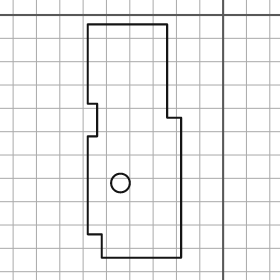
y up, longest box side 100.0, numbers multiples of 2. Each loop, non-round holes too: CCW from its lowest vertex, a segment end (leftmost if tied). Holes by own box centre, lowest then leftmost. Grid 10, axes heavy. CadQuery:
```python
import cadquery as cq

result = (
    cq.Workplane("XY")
    .moveTo(-52.0, -104.0)
    .lineTo(-18.0, -104.0)
    .lineTo(-18.0, -44.0)
    .lineTo(-24.0, -44.0)
    .lineTo(-24.0, -4.0)
    .lineTo(-58.0, -4.0)
    .lineTo(-58.0, -38.0)
    .lineTo(-54.0, -38.0)
    .lineTo(-54.0, -52.0)
    .lineTo(-58.0, -52.0)
    .lineTo(-58.0, -94.0)
    .lineTo(-52.0, -94.0)
    .close()
    .moveTo(-44.0, -72.0)
    .circle(4.0)
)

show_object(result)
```